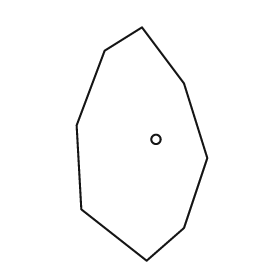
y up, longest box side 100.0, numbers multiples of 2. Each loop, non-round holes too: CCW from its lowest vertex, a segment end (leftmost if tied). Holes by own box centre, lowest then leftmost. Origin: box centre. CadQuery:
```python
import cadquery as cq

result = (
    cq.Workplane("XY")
    .moveTo(2.0, -50.0)
    .lineTo(18.0, -36.0)
    .lineTo(28.0, -6.0)
    .lineTo(18.0, 26.0)
    .lineTo(0.0, 50.0)
    .lineTo(-16.0, 40.0)
    .lineTo(-28.0, 8.0)
    .lineTo(-26.0, -28.0)
    .close()
    .moveTo(6.0, 2.0)
    .circle(2.0)
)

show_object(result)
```